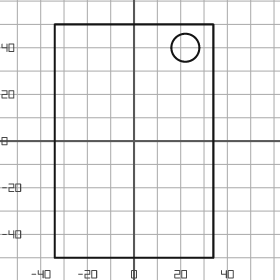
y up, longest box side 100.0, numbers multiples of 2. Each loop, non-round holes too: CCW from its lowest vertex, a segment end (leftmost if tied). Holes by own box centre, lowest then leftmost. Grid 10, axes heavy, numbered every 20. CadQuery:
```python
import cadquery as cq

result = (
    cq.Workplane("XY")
    .moveTo(-34.0, -50.0)
    .lineTo(34.0, -50.0)
    .lineTo(34.0, 50.0)
    .lineTo(-34.0, 50.0)
    .close()
    .moveTo(22.0, 40.0)
    .circle(6.0)
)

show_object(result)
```